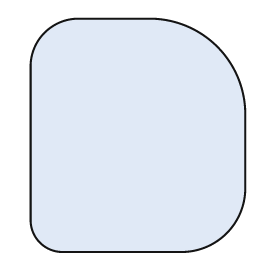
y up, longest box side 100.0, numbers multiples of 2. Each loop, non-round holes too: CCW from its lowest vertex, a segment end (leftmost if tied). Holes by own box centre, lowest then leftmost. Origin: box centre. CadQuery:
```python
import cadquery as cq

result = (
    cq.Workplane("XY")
    .moveTo(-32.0, -50.0)
    .lineTo(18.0, -50.0)
    .threePointArc((38.0, -42.0), (46.0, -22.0))
    .lineTo(46.0, 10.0)
    .threePointArc((34.0, 38.0), (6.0, 50.0))
    .lineTo(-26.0, 50.0)
    .threePointArc((-40.0, 44.0), (-46.0, 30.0))
    .lineTo(-46.0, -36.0)
    .threePointArc((-42.0, -46.0), (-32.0, -50.0))
    .close()
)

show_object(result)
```